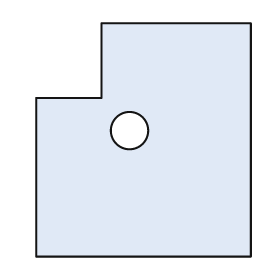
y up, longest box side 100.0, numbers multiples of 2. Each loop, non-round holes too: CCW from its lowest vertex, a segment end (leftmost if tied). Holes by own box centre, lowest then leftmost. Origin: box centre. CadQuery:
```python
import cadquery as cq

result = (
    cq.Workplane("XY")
    .moveTo(-46.0, -50.0)
    .lineTo(46.0, -50.0)
    .lineTo(46.0, 50.0)
    .lineTo(-18.0, 50.0)
    .lineTo(-18.0, 18.0)
    .lineTo(-46.0, 18.0)
    .close()
    .moveTo(-6.0, 4.0)
    .circle(8.0)
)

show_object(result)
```